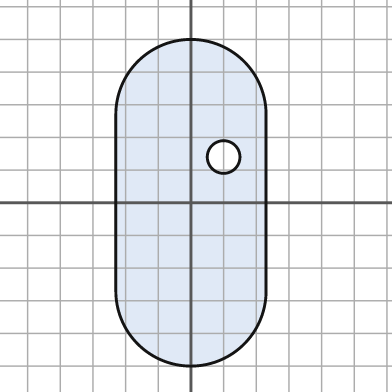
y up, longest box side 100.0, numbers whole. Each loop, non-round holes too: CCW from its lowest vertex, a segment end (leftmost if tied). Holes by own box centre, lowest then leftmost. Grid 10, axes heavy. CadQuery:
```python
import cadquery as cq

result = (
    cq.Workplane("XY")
    .moveTo(-23.0, -27.0)
    .threePointArc((0.0, -50.0), (23.0, -27.0))
    .lineTo(23.0, 27.0)
    .threePointArc((0.0, 50.0), (-23.0, 27.0))
    .close()
    .moveTo(10.0, 14.0)
    .circle(5.0)
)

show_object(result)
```